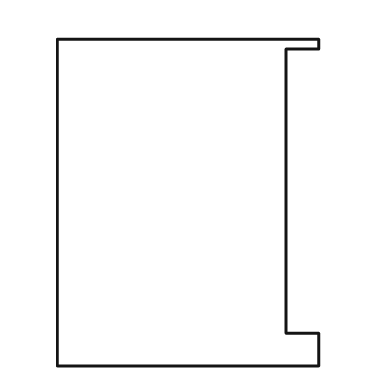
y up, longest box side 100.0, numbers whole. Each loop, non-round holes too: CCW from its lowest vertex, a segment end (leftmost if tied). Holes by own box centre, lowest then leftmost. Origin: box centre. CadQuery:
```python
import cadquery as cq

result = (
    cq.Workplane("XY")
    .moveTo(-40.0, -50.0)
    .lineTo(40.0, -50.0)
    .lineTo(40.0, -40.0)
    .lineTo(30.0, -40.0)
    .lineTo(30.0, 47.0)
    .lineTo(40.0, 47.0)
    .lineTo(40.0, 50.0)
    .lineTo(-40.0, 50.0)
    .close()
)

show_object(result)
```